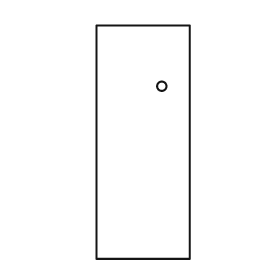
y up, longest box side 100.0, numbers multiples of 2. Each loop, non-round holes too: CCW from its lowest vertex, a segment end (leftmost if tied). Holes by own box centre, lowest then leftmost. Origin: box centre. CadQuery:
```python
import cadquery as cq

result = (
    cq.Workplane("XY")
    .moveTo(-20.0, -50.0)
    .lineTo(20.0, -50.0)
    .lineTo(20.0, 50.0)
    .lineTo(-20.0, 50.0)
    .close()
    .moveTo(8.0, 24.0)
    .circle(2.0)
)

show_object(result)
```